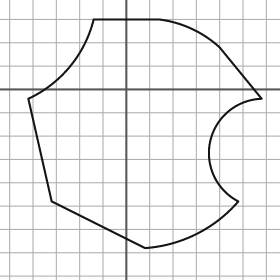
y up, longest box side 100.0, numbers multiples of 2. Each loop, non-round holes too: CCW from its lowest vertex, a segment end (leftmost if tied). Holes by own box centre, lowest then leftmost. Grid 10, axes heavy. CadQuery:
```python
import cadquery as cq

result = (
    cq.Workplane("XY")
    .moveTo(8.0, -68.0)
    .threePointArc((30.0, -62.0), (48.0, -48.0))
    .threePointArc((36.0, -22.0), (58.0, -4.0))
    .lineTo(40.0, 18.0)
    .threePointArc((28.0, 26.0), (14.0, 30.0))
    .lineTo(-14.0, 30.0)
    .threePointArc((-24.0, 10.0), (-42.0, -4.0))
    .lineTo(-32.0, -48.0)
    .close()
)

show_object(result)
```